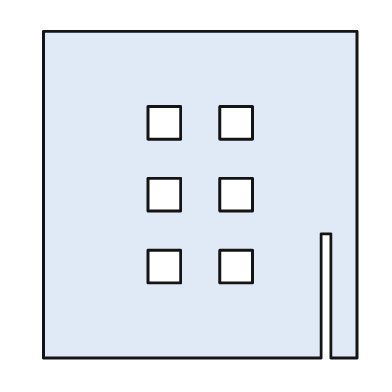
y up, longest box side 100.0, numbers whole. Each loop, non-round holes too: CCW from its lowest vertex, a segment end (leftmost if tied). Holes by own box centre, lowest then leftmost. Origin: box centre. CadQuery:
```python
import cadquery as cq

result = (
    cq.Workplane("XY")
    .moveTo(-48.0, -50.0)
    .lineTo(37.0, -50.0)
    .lineTo(37.0, -12.0)
    .lineTo(40.0, -12.0)
    .lineTo(40.0, -50.0)
    .lineTo(48.0, -50.0)
    .lineTo(48.0, 50.0)
    .lineTo(-48.0, 50.0)
    .close()
    .moveTo(-16.0, -27.0)
    .lineTo(-6.0, -27.0)
    .lineTo(-6.0, -17.0)
    .lineTo(-16.0, -17.0)
    .close()
    .moveTo(6.0, -27.0)
    .lineTo(16.0, -27.0)
    .lineTo(16.0, -17.0)
    .lineTo(6.0, -17.0)
    .close()
    .moveTo(-16.0, -5.0)
    .lineTo(-6.0, -5.0)
    .lineTo(-6.0, 5.0)
    .lineTo(-16.0, 5.0)
    .close()
    .moveTo(6.0, -5.0)
    .lineTo(16.0, -5.0)
    .lineTo(16.0, 5.0)
    .lineTo(6.0, 5.0)
    .close()
    .moveTo(-16.0, 17.0)
    .lineTo(-6.0, 17.0)
    .lineTo(-6.0, 27.0)
    .lineTo(-16.0, 27.0)
    .close()
    .moveTo(6.0, 17.0)
    .lineTo(16.0, 17.0)
    .lineTo(16.0, 27.0)
    .lineTo(6.0, 27.0)
    .close()
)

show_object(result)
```